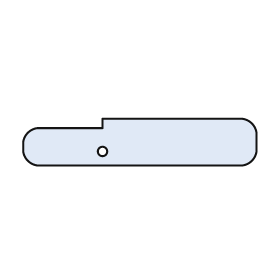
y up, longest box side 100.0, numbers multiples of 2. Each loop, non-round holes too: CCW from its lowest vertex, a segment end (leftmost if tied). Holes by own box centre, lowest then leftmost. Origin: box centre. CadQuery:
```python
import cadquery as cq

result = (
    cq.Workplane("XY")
    .moveTo(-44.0, -10.0)
    .lineTo(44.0, -10.0)
    .threePointArc((48.0, -8.0), (50.0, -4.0))
    .lineTo(50.0, 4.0)
    .threePointArc((48.0, 8.0), (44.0, 10.0))
    .lineTo(-16.0, 10.0)
    .lineTo(-16.0, 6.0)
    .lineTo(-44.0, 6.0)
    .threePointArc((-48.0, 4.0), (-50.0, 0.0))
    .lineTo(-50.0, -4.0)
    .threePointArc((-48.0, -8.0), (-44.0, -10.0))
    .close()
    .moveTo(-16.0, -4.0)
    .circle(2.0)
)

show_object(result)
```